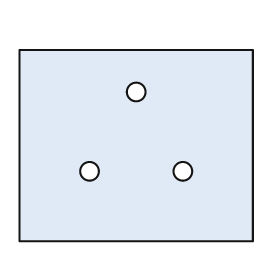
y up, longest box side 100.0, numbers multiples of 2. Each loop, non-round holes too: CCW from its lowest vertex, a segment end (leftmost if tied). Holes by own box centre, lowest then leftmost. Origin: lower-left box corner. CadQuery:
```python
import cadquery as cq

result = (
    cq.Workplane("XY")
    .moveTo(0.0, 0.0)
    .lineTo(100.0, 0.0)
    .lineTo(100.0, 82.0)
    .lineTo(0.0, 82.0)
    .close()
    .moveTo(30.0, 30.0)
    .circle(4.0)
    .moveTo(70.0, 30.0)
    .circle(4.0)
    .moveTo(50.0, 64.0)
    .circle(4.0)
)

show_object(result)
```